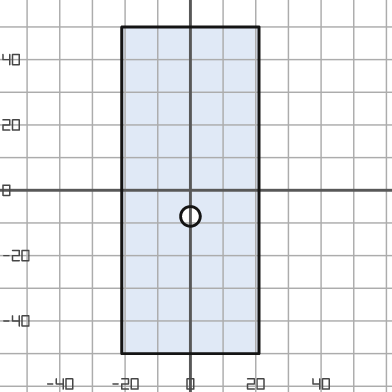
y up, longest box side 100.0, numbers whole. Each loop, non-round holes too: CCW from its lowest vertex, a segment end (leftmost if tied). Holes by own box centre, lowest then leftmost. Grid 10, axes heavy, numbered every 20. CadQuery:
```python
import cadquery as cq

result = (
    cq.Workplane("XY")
    .moveTo(-21.0, -50.0)
    .lineTo(21.0, -50.0)
    .lineTo(21.0, 50.0)
    .lineTo(-21.0, 50.0)
    .close()
    .moveTo(0.0, -8.0)
    .circle(3.0)
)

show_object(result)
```